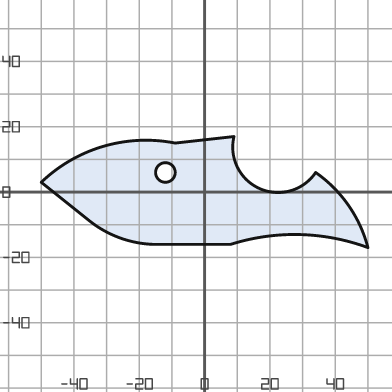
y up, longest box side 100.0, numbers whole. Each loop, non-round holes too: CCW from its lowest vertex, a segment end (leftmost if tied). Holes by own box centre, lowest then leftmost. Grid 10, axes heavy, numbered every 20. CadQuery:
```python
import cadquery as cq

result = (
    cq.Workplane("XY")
    .moveTo(50.0, -17.0)
    .threePointArc((44.0, -4.0), (34.0, 6.0))
    .threePointArc((17.0, 1.0), (9.0, 17.0))
    .lineTo(-9.0, 15.0)
    .threePointArc((-31.0, 14.0), (-50.0, 3.0))
    .lineTo(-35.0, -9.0)
    .threePointArc((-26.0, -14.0), (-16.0, -16.0))
    .lineTo(8.0, -16.0)
    .threePointArc((29.0, -13.0), (50.0, -17.0))
    .close()
    .moveTo(-12.0, 6.0)
    .circle(3.0)
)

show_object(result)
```